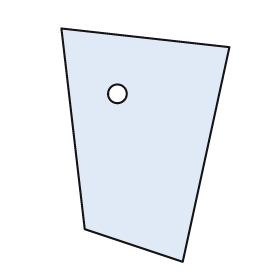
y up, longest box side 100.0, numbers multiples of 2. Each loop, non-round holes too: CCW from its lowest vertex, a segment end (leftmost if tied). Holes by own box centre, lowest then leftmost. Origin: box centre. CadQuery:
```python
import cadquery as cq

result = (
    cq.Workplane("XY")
    .moveTo(16.0, -50.0)
    .lineTo(36.0, 42.0)
    .lineTo(-36.0, 50.0)
    .lineTo(-26.0, -36.0)
    .close()
    .moveTo(-12.0, 22.0)
    .circle(4.0)
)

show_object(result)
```